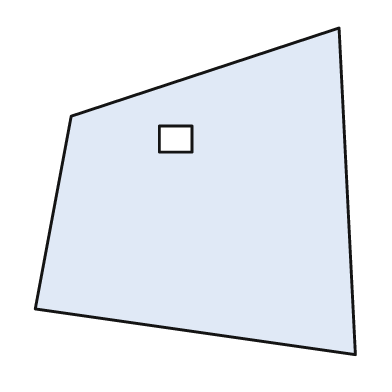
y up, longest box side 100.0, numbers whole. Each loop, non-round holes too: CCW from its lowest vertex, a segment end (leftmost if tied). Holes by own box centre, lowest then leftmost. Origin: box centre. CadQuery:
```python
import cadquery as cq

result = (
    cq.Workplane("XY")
    .moveTo(49.0, -50.0)
    .lineTo(44.0, 50.0)
    .lineTo(-38.0, 23.0)
    .lineTo(-49.0, -36.0)
    .close()
    .moveTo(-11.0, 12.0)
    .lineTo(-1.0, 12.0)
    .lineTo(-1.0, 20.0)
    .lineTo(-11.0, 20.0)
    .close()
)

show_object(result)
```